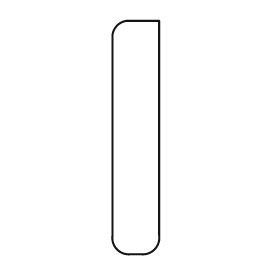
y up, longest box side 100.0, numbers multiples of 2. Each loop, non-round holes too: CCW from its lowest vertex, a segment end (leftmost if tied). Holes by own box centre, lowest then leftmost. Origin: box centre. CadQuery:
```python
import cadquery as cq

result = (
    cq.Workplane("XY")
    .moveTo(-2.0, -50.0)
    .lineTo(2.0, -50.0)
    .threePointArc((8.0, -48.0), (10.0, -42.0))
    .lineTo(10.0, 50.0)
    .lineTo(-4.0, 50.0)
    .threePointArc((-8.0, 48.0), (-10.0, 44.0))
    .lineTo(-10.0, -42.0)
    .threePointArc((-8.0, -48.0), (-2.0, -50.0))
    .close()
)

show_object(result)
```